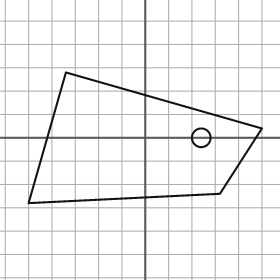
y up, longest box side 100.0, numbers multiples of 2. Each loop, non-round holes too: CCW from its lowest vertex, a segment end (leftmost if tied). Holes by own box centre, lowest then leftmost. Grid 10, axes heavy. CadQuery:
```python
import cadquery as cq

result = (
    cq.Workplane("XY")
    .moveTo(-50.0, -28.0)
    .lineTo(32.0, -24.0)
    .lineTo(50.0, 4.0)
    .lineTo(-34.0, 28.0)
    .close()
    .moveTo(24.0, 0.0)
    .circle(4.0)
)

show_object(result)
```